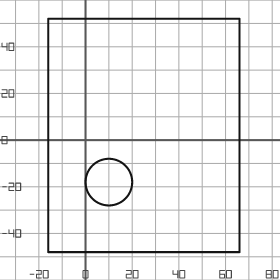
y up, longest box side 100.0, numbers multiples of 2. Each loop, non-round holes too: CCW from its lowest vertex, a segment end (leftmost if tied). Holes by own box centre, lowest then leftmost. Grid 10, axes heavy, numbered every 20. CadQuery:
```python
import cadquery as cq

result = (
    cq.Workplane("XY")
    .moveTo(-16.0, -48.0)
    .lineTo(66.0, -48.0)
    .lineTo(66.0, 52.0)
    .lineTo(-16.0, 52.0)
    .close()
    .moveTo(10.0, -18.0)
    .circle(10.0)
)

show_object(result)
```